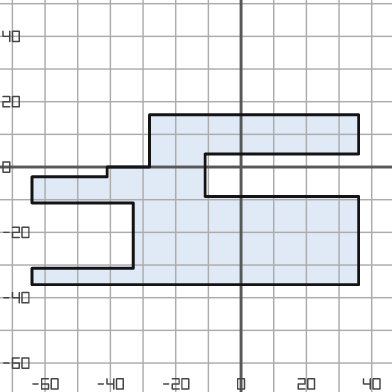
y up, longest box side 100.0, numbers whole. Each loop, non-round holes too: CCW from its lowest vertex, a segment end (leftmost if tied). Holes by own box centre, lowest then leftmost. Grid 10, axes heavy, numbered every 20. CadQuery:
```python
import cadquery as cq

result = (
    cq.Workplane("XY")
    .moveTo(-64.0, -36.0)
    .lineTo(36.0, -36.0)
    .lineTo(36.0, -9.0)
    .lineTo(-11.0, -9.0)
    .lineTo(-11.0, 4.0)
    .lineTo(36.0, 4.0)
    .lineTo(36.0, 16.0)
    .lineTo(-28.0, 16.0)
    .lineTo(-28.0, 0.0)
    .lineTo(-41.0, 0.0)
    .lineTo(-41.0, -3.0)
    .lineTo(-64.0, -3.0)
    .lineTo(-64.0, -11.0)
    .lineTo(-33.0, -11.0)
    .lineTo(-33.0, -31.0)
    .lineTo(-64.0, -31.0)
    .close()
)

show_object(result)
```